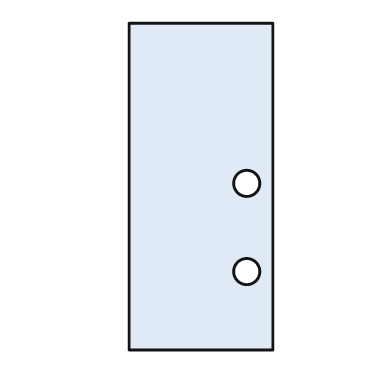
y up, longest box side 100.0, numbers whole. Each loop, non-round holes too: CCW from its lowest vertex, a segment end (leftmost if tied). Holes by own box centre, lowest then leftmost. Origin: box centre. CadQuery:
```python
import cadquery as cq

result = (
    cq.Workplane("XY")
    .moveTo(-22.0, -50.0)
    .lineTo(22.0, -50.0)
    .lineTo(22.0, 50.0)
    .lineTo(-22.0, 50.0)
    .close()
    .moveTo(14.0, -26.0)
    .circle(4.0)
    .moveTo(14.0, 1.0)
    .circle(4.0)
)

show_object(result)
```